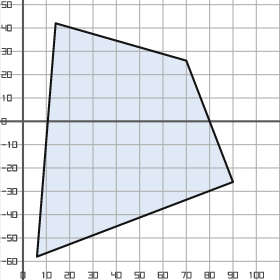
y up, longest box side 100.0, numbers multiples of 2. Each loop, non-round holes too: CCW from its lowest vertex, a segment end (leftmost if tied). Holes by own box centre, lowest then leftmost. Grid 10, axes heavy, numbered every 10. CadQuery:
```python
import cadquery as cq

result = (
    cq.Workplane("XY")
    .moveTo(6.0, -58.0)
    .lineTo(90.0, -26.0)
    .lineTo(70.0, 26.0)
    .lineTo(14.0, 42.0)
    .close()
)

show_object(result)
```